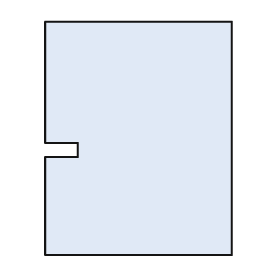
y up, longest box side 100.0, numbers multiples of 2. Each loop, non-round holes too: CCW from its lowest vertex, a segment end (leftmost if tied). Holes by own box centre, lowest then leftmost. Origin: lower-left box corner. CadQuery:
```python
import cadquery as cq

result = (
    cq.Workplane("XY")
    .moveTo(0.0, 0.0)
    .lineTo(80.0, 0.0)
    .lineTo(80.0, 100.0)
    .lineTo(0.0, 100.0)
    .lineTo(0.0, 48.0)
    .lineTo(14.0, 48.0)
    .lineTo(14.0, 42.0)
    .lineTo(0.0, 42.0)
    .close()
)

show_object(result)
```